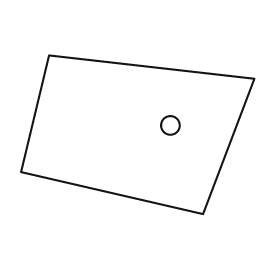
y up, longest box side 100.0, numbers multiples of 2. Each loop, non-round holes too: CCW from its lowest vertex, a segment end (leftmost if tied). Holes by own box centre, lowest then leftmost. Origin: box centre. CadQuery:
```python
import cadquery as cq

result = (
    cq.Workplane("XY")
    .moveTo(28.0, -34.0)
    .lineTo(50.0, 24.0)
    .lineTo(-38.0, 34.0)
    .lineTo(-50.0, -16.0)
    .close()
    .moveTo(14.0, 4.0)
    .circle(4.0)
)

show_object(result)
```